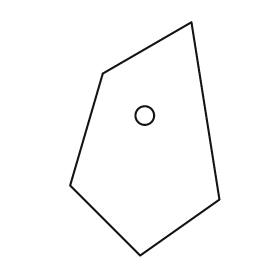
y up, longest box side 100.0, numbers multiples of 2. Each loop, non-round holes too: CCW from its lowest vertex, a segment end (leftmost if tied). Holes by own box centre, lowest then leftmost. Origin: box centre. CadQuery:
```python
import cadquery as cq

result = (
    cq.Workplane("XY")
    .moveTo(-2.0, -50.0)
    .lineTo(32.0, -26.0)
    .lineTo(20.0, 50.0)
    .lineTo(-18.0, 28.0)
    .lineTo(-32.0, -20.0)
    .close()
    .moveTo(0.0, 10.0)
    .circle(4.0)
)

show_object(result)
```